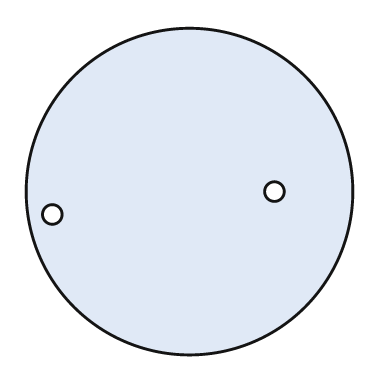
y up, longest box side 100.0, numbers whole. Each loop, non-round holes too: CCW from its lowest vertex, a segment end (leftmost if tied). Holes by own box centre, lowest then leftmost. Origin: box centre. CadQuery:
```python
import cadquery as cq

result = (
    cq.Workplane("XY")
    .moveTo(0.0, 0.0)
    .circle(50.0)
    .moveTo(-42.0, -7.0)
    .circle(3.0)
    .moveTo(26.0, 0.0)
    .circle(3.0)
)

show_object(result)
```